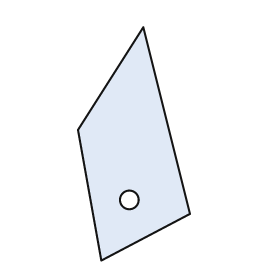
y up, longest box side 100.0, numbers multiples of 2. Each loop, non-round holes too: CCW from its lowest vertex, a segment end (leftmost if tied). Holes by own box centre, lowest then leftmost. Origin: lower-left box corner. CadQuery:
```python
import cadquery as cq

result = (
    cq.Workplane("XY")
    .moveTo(10.0, 0.0)
    .lineTo(48.0, 20.0)
    .lineTo(28.0, 100.0)
    .lineTo(0.0, 56.0)
    .close()
    .moveTo(22.0, 26.0)
    .circle(4.0)
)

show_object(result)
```